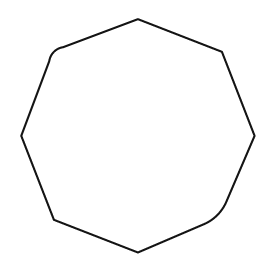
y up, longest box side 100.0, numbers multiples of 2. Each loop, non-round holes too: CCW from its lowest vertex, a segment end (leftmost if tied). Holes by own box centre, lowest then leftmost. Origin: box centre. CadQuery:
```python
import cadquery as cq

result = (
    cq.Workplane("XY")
    .moveTo(0.0, -50.0)
    .lineTo(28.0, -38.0)
    .threePointArc((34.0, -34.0), (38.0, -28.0))
    .lineTo(50.0, 0.0)
    .lineTo(36.0, 36.0)
    .lineTo(0.0, 50.0)
    .lineTo(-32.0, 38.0)
    .threePointArc((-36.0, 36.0), (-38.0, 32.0))
    .lineTo(-50.0, 0.0)
    .lineTo(-36.0, -36.0)
    .close()
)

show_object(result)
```